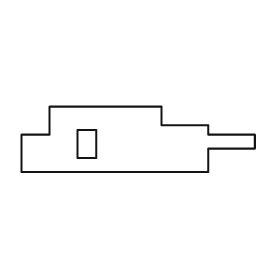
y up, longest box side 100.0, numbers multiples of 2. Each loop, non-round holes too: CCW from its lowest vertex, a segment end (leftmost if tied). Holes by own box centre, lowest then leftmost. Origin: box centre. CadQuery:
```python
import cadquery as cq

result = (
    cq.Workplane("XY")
    .moveTo(-50.0, -14.0)
    .lineTo(30.0, -14.0)
    .lineTo(30.0, -4.0)
    .lineTo(50.0, -4.0)
    .lineTo(50.0, 2.0)
    .lineTo(30.0, 2.0)
    .lineTo(30.0, 6.0)
    .lineTo(10.0, 6.0)
    .lineTo(10.0, 14.0)
    .lineTo(-38.0, 14.0)
    .lineTo(-38.0, 2.0)
    .lineTo(-50.0, 2.0)
    .close()
    .moveTo(-26.0, -8.0)
    .lineTo(-18.0, -8.0)
    .lineTo(-18.0, 4.0)
    .lineTo(-26.0, 4.0)
    .close()
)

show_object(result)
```